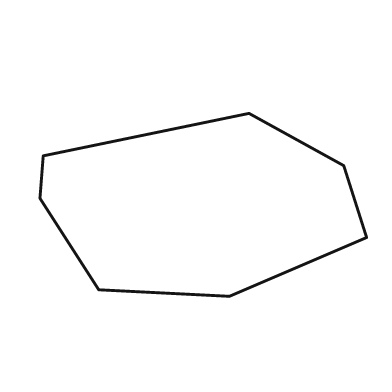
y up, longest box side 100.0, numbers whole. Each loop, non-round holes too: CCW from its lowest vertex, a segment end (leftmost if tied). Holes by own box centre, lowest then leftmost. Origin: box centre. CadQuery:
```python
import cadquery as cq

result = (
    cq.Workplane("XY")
    .moveTo(8.0, -28.0)
    .lineTo(50.0, -10.0)
    .lineTo(43.0, 12.0)
    .lineTo(14.0, 28.0)
    .lineTo(-49.0, 15.0)
    .lineTo(-50.0, 2.0)
    .lineTo(-32.0, -26.0)
    .close()
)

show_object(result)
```